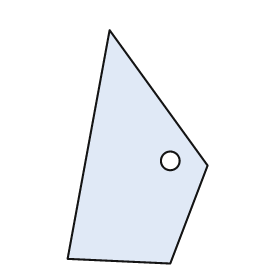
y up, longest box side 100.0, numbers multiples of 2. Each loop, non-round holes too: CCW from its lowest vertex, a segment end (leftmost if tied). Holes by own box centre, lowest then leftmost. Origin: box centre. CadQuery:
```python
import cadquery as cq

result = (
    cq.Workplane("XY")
    .moveTo(14.0, -50.0)
    .lineTo(30.0, -8.0)
    .lineTo(-12.0, 50.0)
    .lineTo(-30.0, -48.0)
    .close()
    .moveTo(14.0, -6.0)
    .circle(4.0)
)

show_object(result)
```